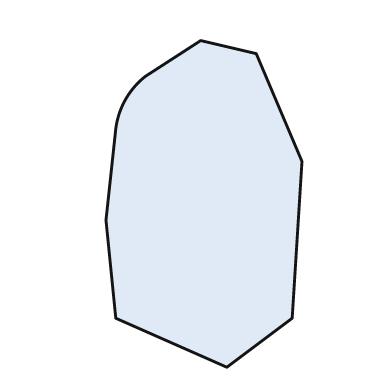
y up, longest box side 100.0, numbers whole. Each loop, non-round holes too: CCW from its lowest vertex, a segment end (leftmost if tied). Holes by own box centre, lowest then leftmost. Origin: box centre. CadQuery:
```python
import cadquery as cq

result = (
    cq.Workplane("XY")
    .moveTo(7.0, -50.0)
    .lineTo(27.0, -35.0)
    .lineTo(30.0, 13.0)
    .lineTo(16.0, 46.0)
    .lineTo(-1.0, 50.0)
    .lineTo(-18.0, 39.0)
    .threePointArc((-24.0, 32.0), (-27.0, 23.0))
    .lineTo(-30.0, -5.0)
    .lineTo(-27.0, -35.0)
    .close()
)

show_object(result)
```